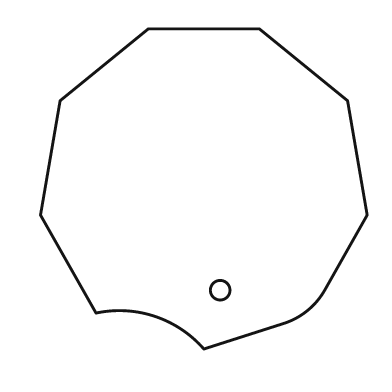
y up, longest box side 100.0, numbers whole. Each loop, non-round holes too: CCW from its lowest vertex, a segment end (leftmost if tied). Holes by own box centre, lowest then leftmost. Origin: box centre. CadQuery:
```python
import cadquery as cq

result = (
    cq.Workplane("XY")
    .moveTo(0.0, -49.0)
    .lineTo(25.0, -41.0)
    .threePointArc((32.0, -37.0), (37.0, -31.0))
    .lineTo(50.0, -8.0)
    .lineTo(44.0, 27.0)
    .lineTo(17.0, 49.0)
    .lineTo(-17.0, 49.0)
    .lineTo(-44.0, 27.0)
    .lineTo(-50.0, -8.0)
    .lineTo(-33.0, -38.0)
    .threePointArc((-15.0, -39.0), (0.0, -49.0))
    .close()
    .moveTo(5.0, -31.0)
    .circle(3.0)
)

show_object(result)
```